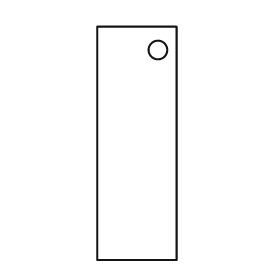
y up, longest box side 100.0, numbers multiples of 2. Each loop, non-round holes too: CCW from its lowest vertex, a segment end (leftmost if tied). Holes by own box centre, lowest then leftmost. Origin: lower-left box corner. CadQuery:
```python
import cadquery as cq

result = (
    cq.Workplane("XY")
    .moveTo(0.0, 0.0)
    .lineTo(34.0, 0.0)
    .lineTo(34.0, 100.0)
    .lineTo(0.0, 100.0)
    .close()
    .moveTo(26.0, 90.0)
    .circle(4.0)
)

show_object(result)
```